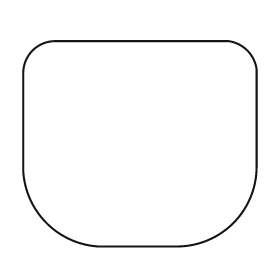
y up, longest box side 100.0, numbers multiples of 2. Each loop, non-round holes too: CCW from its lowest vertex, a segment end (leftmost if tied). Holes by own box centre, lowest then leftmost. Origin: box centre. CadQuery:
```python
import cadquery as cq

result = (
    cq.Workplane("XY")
    .moveTo(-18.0, -44.0)
    .lineTo(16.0, -44.0)
    .threePointArc((40.0, -34.0), (50.0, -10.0))
    .lineTo(50.0, 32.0)
    .threePointArc((46.0, 40.0), (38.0, 44.0))
    .lineTo(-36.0, 44.0)
    .threePointArc((-46.0, 40.0), (-50.0, 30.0))
    .lineTo(-50.0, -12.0)
    .threePointArc((-40.0, -34.0), (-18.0, -44.0))
    .close()
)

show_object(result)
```